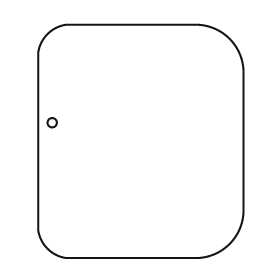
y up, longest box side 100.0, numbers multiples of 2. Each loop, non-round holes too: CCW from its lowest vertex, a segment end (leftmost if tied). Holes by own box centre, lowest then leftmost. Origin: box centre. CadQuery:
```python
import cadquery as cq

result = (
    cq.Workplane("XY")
    .moveTo(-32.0, -50.0)
    .lineTo(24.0, -50.0)
    .threePointArc((38.0, -44.0), (44.0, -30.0))
    .lineTo(44.0, 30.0)
    .threePointArc((38.0, 44.0), (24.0, 50.0))
    .lineTo(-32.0, 50.0)
    .threePointArc((-40.0, 46.0), (-44.0, 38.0))
    .lineTo(-44.0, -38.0)
    .threePointArc((-40.0, -46.0), (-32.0, -50.0))
    .close()
    .moveTo(-38.0, 8.0)
    .circle(2.0)
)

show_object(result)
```